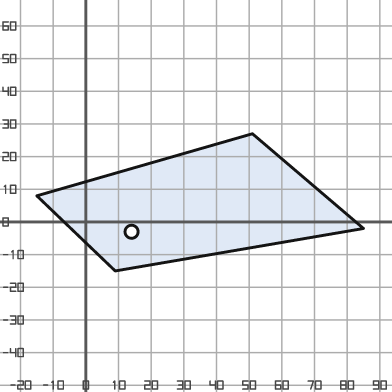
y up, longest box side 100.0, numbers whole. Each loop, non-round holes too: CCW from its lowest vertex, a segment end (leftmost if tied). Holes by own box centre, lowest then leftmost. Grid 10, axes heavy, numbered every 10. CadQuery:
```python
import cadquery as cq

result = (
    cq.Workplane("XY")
    .moveTo(9.0, -15.0)
    .lineTo(85.0, -2.0)
    .lineTo(51.0, 27.0)
    .lineTo(-15.0, 8.0)
    .close()
    .moveTo(14.0, -3.0)
    .circle(2.0)
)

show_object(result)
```